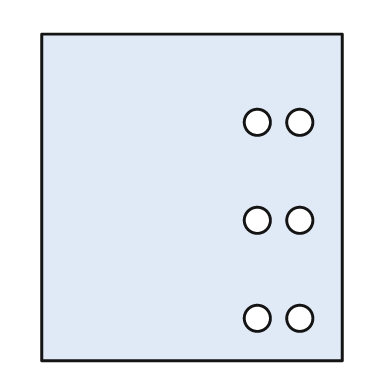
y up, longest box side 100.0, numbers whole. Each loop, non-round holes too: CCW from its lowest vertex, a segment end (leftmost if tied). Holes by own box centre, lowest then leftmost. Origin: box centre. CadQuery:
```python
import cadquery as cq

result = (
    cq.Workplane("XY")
    .moveTo(-46.0, -50.0)
    .lineTo(46.0, -50.0)
    .lineTo(46.0, 50.0)
    .lineTo(-46.0, 50.0)
    .close()
    .moveTo(20.0, -37.0)
    .circle(4.0)
    .moveTo(33.0, -37.0)
    .circle(4.0)
    .moveTo(20.0, -7.0)
    .circle(4.0)
    .moveTo(33.0, -7.0)
    .circle(4.0)
    .moveTo(20.0, 23.0)
    .circle(4.0)
    .moveTo(33.0, 23.0)
    .circle(4.0)
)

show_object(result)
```